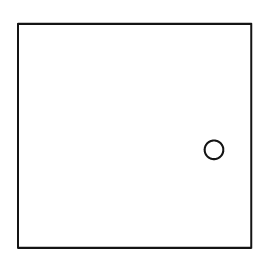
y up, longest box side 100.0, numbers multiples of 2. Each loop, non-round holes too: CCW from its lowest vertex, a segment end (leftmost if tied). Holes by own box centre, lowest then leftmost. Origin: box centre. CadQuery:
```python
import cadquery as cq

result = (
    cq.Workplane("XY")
    .moveTo(-50.0, -48.0)
    .lineTo(50.0, -48.0)
    .lineTo(50.0, 48.0)
    .lineTo(-50.0, 48.0)
    .close()
    .moveTo(34.0, -6.0)
    .circle(4.0)
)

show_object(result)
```